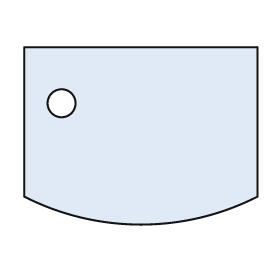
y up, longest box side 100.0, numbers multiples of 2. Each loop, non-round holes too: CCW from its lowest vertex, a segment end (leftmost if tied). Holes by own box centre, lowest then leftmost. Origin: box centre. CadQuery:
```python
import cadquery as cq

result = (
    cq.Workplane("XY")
    .moveTo(-50.0, -26.0)
    .threePointArc((0.0, -38.0), (50.0, -26.0))
    .lineTo(50.0, 38.0)
    .lineTo(-50.0, 38.0)
    .close()
    .moveTo(-34.0, 14.0)
    .circle(6.0)
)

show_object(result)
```